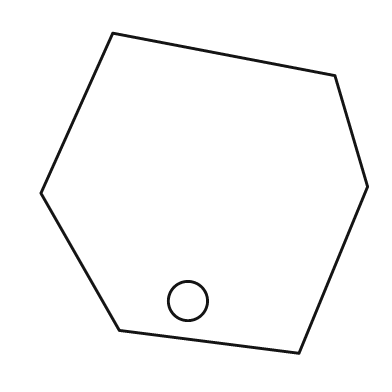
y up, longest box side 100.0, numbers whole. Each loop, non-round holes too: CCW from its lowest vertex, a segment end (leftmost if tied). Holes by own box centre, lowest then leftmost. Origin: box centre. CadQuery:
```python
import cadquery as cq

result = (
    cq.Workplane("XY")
    .moveTo(29.0, -49.0)
    .lineTo(50.0, 2.0)
    .lineTo(40.0, 36.0)
    .lineTo(-28.0, 49.0)
    .lineTo(-50.0, 0.0)
    .lineTo(-26.0, -42.0)
    .close()
    .moveTo(-5.0, -33.0)
    .circle(6.0)
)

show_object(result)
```